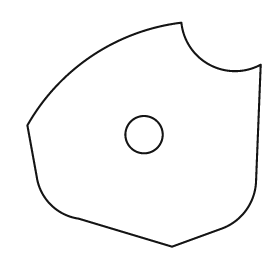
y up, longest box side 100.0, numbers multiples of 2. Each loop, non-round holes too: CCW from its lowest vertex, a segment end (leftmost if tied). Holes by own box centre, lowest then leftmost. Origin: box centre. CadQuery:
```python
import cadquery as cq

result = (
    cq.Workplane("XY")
    .moveTo(12.0, -48.0)
    .lineTo(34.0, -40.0)
    .threePointArc((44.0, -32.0), (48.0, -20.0))
    .lineTo(50.0, 30.0)
    .threePointArc((28.0, 30.0), (16.0, 48.0))
    .threePointArc((-22.0, 34.0), (-50.0, 4.0))
    .lineTo(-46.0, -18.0)
    .threePointArc((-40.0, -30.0), (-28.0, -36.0))
    .close()
    .moveTo(0.0, 0.0)
    .circle(8.0)
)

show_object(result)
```